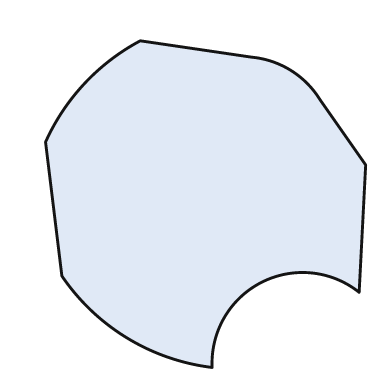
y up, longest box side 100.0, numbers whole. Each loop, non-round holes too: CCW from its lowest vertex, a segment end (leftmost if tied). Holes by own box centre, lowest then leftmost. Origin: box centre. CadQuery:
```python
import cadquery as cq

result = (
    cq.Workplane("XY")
    .moveTo(2.0, -50.0)
    .threePointArc((17.0, -24.0), (47.0, -27.0))
    .lineTo(49.0, 12.0)
    .lineTo(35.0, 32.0)
    .threePointArc((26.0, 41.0), (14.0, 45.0))
    .lineTo(-20.0, 50.0)
    .threePointArc((-37.0, 37.0), (-49.0, 19.0))
    .lineTo(-44.0, -22.0)
    .threePointArc((-24.0, -41.0), (2.0, -50.0))
    .close()
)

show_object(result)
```